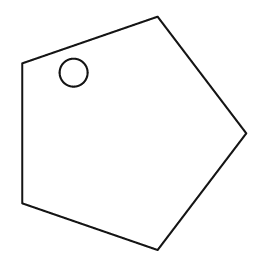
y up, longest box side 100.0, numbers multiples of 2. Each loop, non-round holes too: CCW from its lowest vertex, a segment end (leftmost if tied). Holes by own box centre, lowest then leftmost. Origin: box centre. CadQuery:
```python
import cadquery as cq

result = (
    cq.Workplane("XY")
    .moveTo(10.0, -50.0)
    .lineTo(48.0, 0.0)
    .lineTo(10.0, 50.0)
    .lineTo(-48.0, 30.0)
    .lineTo(-48.0, -30.0)
    .close()
    .moveTo(-26.0, 26.0)
    .circle(6.0)
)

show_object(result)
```